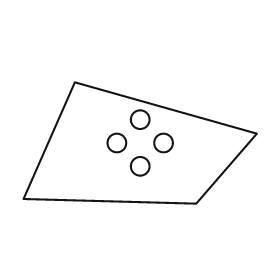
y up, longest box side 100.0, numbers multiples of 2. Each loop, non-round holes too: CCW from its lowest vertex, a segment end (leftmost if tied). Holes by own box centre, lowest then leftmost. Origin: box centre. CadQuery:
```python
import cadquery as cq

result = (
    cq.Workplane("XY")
    .moveTo(24.0, -26.0)
    .lineTo(50.0, 4.0)
    .lineTo(-28.0, 26.0)
    .lineTo(-50.0, -24.0)
    .close()
    .moveTo(0.0, -10.0)
    .circle(4.0)
    .moveTo(-10.0, 0.0)
    .circle(4.0)
    .moveTo(10.0, 0.0)
    .circle(4.0)
    .moveTo(0.0, 10.0)
    .circle(4.0)
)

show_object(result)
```